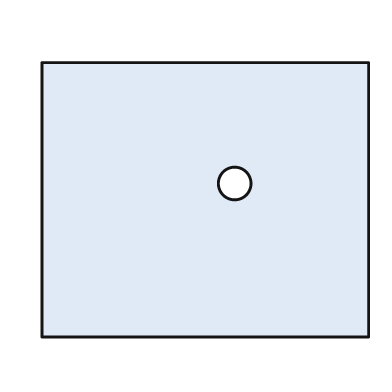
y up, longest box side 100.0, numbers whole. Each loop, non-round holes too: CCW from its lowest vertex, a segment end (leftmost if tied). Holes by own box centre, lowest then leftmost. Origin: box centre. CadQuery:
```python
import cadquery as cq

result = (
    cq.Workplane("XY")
    .moveTo(-50.0, -42.0)
    .lineTo(50.0, -42.0)
    .lineTo(50.0, 42.0)
    .lineTo(-50.0, 42.0)
    .close()
    .moveTo(9.0, 5.0)
    .circle(5.0)
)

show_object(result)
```